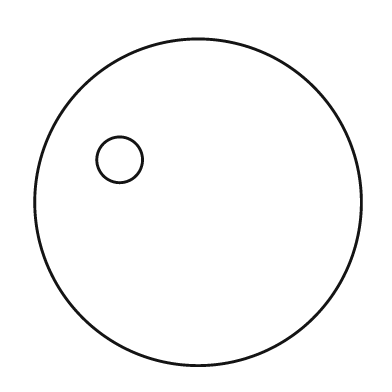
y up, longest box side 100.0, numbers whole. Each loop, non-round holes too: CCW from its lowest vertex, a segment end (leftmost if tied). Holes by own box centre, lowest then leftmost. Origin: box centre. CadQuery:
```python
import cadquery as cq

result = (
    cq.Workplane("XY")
    .moveTo(0.0, 0.0)
    .circle(50.0)
    .moveTo(-24.0, 13.0)
    .circle(7.0)
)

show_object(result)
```